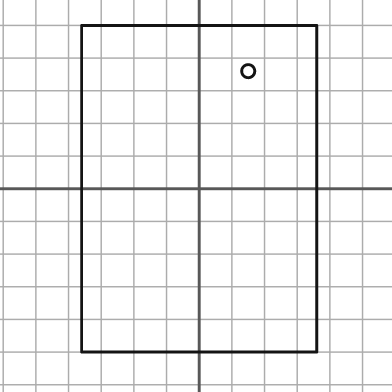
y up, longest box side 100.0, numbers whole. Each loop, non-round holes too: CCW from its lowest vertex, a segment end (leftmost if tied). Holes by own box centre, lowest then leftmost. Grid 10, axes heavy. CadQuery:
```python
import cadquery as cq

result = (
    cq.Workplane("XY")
    .moveTo(-36.0, -50.0)
    .lineTo(36.0, -50.0)
    .lineTo(36.0, 50.0)
    .lineTo(-36.0, 50.0)
    .close()
    .moveTo(15.0, 36.0)
    .circle(2.0)
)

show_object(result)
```